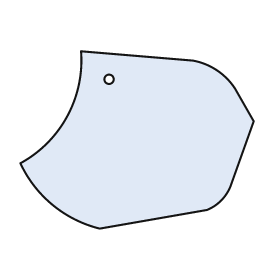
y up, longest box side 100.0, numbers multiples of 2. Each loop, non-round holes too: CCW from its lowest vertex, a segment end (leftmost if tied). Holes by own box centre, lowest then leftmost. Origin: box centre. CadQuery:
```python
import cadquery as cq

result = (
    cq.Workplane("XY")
    .moveTo(-16.0, -38.0)
    .lineTo(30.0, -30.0)
    .threePointArc((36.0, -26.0), (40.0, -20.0))
    .lineTo(50.0, 8.0)
    .lineTo(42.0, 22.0)
    .threePointArc((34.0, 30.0), (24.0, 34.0))
    .lineTo(-24.0, 38.0)
    .threePointArc((-30.0, 10.0), (-50.0, -10.0))
    .threePointArc((-36.0, -28.0), (-16.0, -38.0))
    .close()
    .moveTo(-12.0, 26.0)
    .circle(2.0)
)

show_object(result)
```